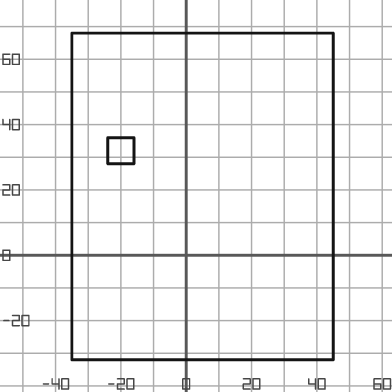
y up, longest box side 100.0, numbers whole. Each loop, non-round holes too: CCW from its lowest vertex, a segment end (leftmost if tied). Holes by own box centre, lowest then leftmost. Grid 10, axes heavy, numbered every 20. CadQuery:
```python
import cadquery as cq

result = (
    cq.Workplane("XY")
    .moveTo(-35.0, -32.0)
    .lineTo(45.0, -32.0)
    .lineTo(45.0, 68.0)
    .lineTo(-35.0, 68.0)
    .close()
    .moveTo(-24.0, 28.0)
    .lineTo(-16.0, 28.0)
    .lineTo(-16.0, 36.0)
    .lineTo(-24.0, 36.0)
    .close()
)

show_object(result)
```